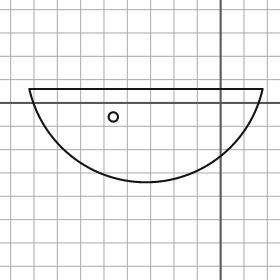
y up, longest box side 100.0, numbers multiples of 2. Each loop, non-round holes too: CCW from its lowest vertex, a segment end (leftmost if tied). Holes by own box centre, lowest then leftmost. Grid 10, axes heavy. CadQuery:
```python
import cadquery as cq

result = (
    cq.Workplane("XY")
    .moveTo(-82.0, 6.0)
    .threePointArc((-32.0, -34.0), (18.0, 6.0))
    .close()
    .moveTo(-46.0, -6.0)
    .circle(2.0)
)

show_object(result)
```